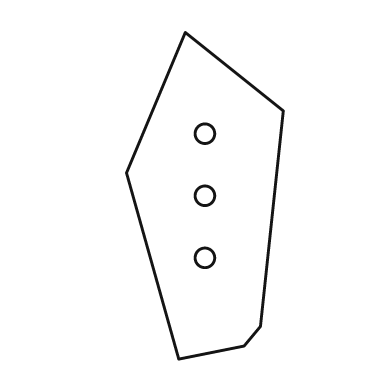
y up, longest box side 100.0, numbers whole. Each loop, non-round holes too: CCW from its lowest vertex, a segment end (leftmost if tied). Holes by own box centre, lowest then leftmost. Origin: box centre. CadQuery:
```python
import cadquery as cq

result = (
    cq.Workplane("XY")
    .moveTo(-8.0, -50.0)
    .lineTo(12.0, -46.0)
    .lineTo(17.0, -40.0)
    .lineTo(24.0, 26.0)
    .lineTo(-6.0, 50.0)
    .lineTo(-24.0, 7.0)
    .close()
    .moveTo(0.0, -19.0)
    .circle(3.0)
    .moveTo(0.0, 0.0)
    .circle(3.0)
    .moveTo(0.0, 19.0)
    .circle(3.0)
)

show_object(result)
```